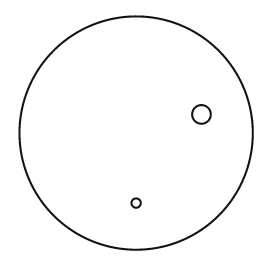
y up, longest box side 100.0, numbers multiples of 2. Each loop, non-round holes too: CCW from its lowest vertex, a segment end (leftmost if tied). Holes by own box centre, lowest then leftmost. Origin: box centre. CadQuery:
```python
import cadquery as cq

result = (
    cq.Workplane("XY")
    .moveTo(0.0, 0.0)
    .circle(50.0)
    .moveTo(0.0, -30.0)
    .circle(2.0)
    .moveTo(28.0, 8.0)
    .circle(4.0)
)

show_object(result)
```